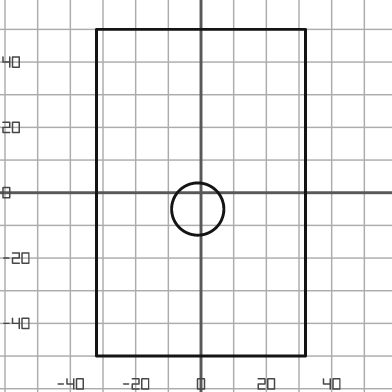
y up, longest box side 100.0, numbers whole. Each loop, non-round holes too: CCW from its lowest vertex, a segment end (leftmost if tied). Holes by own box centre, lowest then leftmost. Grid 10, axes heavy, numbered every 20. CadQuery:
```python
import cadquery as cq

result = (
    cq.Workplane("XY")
    .moveTo(-32.0, -50.0)
    .lineTo(32.0, -50.0)
    .lineTo(32.0, 50.0)
    .lineTo(-32.0, 50.0)
    .close()
    .moveTo(-1.0, -5.0)
    .circle(8.0)
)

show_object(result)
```